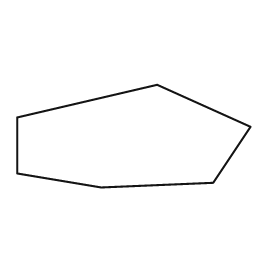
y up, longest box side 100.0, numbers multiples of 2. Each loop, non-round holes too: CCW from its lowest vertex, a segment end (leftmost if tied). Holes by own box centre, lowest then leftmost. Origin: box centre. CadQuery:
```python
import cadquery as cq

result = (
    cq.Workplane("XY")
    .moveTo(-14.0, -22.0)
    .lineTo(34.0, -20.0)
    .lineTo(50.0, 4.0)
    .lineTo(10.0, 22.0)
    .lineTo(-50.0, 8.0)
    .lineTo(-50.0, -16.0)
    .close()
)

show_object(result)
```